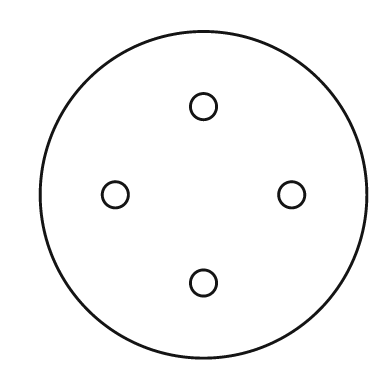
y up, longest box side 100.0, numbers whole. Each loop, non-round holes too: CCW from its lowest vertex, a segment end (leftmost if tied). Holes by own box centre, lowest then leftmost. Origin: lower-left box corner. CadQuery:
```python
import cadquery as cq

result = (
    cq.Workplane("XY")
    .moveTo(50.0, 50.0)
    .circle(50.0)
    .moveTo(50.0, 23.0)
    .circle(4.0)
    .moveTo(23.0, 50.0)
    .circle(4.0)
    .moveTo(77.0, 50.0)
    .circle(4.0)
    .moveTo(50.0, 77.0)
    .circle(4.0)
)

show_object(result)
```